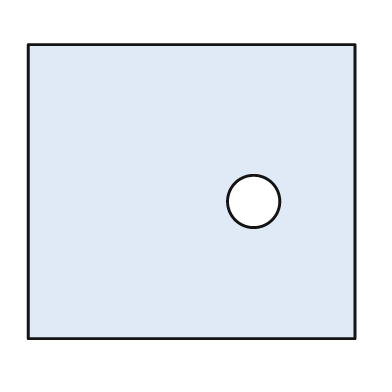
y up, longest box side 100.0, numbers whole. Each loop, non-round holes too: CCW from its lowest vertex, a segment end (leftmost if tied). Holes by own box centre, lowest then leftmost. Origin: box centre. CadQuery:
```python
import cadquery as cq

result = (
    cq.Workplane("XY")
    .moveTo(-50.0, -45.0)
    .lineTo(50.0, -45.0)
    .lineTo(50.0, 45.0)
    .lineTo(-50.0, 45.0)
    .close()
    .moveTo(19.0, -3.0)
    .circle(8.0)
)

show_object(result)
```